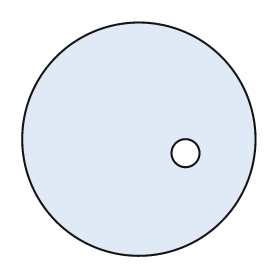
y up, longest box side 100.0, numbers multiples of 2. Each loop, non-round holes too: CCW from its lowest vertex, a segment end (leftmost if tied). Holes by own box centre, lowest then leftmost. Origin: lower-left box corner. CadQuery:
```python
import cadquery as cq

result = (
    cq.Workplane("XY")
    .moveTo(50.0, 50.0)
    .circle(50.0)
    .moveTo(70.0, 44.0)
    .circle(6.0)
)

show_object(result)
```